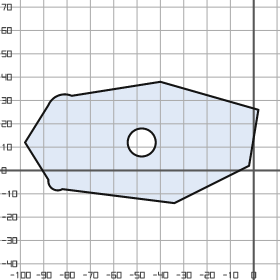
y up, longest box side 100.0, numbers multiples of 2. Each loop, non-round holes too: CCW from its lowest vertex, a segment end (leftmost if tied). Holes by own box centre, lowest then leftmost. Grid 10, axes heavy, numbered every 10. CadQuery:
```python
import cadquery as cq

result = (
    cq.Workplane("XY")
    .moveTo(-34.0, -14.0)
    .lineTo(-2.0, 2.0)
    .lineTo(2.0, 26.0)
    .lineTo(-40.0, 38.0)
    .lineTo(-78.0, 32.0)
    .threePointArc((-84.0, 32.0), (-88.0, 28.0))
    .lineTo(-98.0, 12.0)
    .lineTo(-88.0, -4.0)
    .threePointArc((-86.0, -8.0), (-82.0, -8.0))
    .close()
    .moveTo(-48.0, 12.0)
    .circle(6.0)
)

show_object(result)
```